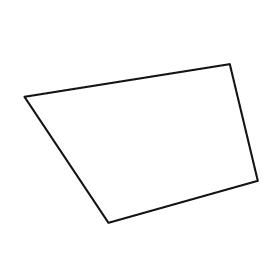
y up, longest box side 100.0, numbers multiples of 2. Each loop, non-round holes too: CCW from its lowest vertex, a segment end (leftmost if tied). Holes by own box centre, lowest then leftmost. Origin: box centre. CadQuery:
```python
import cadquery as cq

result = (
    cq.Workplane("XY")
    .moveTo(-14.0, -34.0)
    .lineTo(50.0, -16.0)
    .lineTo(38.0, 34.0)
    .lineTo(-50.0, 20.0)
    .close()
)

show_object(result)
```